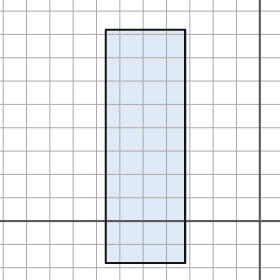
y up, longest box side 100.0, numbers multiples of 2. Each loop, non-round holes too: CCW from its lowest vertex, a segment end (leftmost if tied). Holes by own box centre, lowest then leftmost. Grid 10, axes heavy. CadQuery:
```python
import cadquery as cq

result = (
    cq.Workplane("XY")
    .moveTo(-66.0, -18.0)
    .lineTo(-32.0, -18.0)
    .lineTo(-32.0, 82.0)
    .lineTo(-66.0, 82.0)
    .close()
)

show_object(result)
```